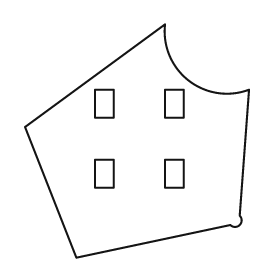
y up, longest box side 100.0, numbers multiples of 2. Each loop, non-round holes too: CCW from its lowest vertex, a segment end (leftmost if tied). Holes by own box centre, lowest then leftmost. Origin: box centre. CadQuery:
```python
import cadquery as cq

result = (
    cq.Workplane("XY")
    .moveTo(-26.0, -50.0)
    .lineTo(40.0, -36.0)
    .threePointArc((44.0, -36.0), (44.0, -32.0))
    .lineTo(48.0, 22.0)
    .threePointArc((22.0, 26.0), (12.0, 50.0))
    .lineTo(-48.0, 6.0)
    .close()
    .moveTo(-18.0, -20.0)
    .lineTo(-10.0, -20.0)
    .lineTo(-10.0, -8.0)
    .lineTo(-18.0, -8.0)
    .close()
    .moveTo(12.0, -20.0)
    .lineTo(20.0, -20.0)
    .lineTo(20.0, -8.0)
    .lineTo(12.0, -8.0)
    .close()
    .moveTo(-18.0, 10.0)
    .lineTo(-10.0, 10.0)
    .lineTo(-10.0, 22.0)
    .lineTo(-18.0, 22.0)
    .close()
    .moveTo(12.0, 10.0)
    .lineTo(20.0, 10.0)
    .lineTo(20.0, 22.0)
    .lineTo(12.0, 22.0)
    .close()
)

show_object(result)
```